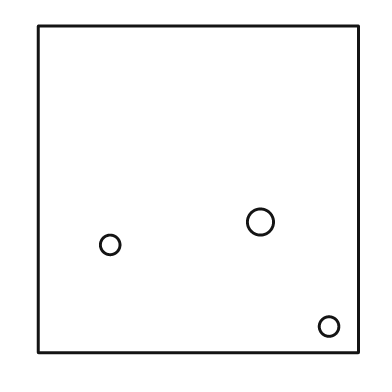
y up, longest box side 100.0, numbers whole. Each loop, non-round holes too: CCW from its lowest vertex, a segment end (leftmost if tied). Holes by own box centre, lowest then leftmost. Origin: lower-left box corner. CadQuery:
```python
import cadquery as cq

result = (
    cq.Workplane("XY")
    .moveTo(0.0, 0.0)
    .lineTo(98.0, 0.0)
    .lineTo(98.0, 100.0)
    .lineTo(0.0, 100.0)
    .close()
    .moveTo(89.0, 8.0)
    .circle(3.0)
    .moveTo(22.0, 33.0)
    .circle(3.0)
    .moveTo(68.0, 40.0)
    .circle(4.0)
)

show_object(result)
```